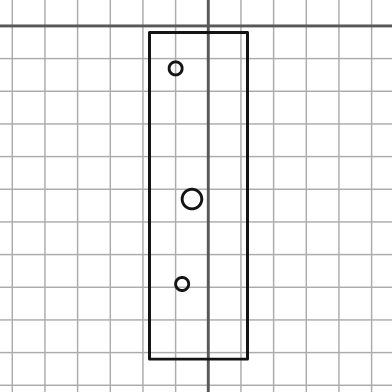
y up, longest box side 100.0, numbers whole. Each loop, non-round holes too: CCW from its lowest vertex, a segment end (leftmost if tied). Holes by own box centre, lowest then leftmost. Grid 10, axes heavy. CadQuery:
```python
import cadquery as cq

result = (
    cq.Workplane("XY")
    .moveTo(-18.0, -102.0)
    .lineTo(12.0, -102.0)
    .lineTo(12.0, -2.0)
    .lineTo(-18.0, -2.0)
    .close()
    .moveTo(-8.0, -79.0)
    .circle(2.0)
    .moveTo(-5.0, -53.0)
    .circle(3.0)
    .moveTo(-10.0, -13.0)
    .circle(2.0)
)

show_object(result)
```